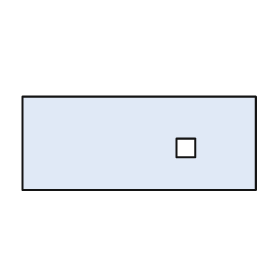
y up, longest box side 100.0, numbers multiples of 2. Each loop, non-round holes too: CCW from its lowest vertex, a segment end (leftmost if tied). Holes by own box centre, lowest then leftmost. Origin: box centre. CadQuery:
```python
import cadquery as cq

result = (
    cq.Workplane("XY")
    .moveTo(-50.0, -20.0)
    .lineTo(50.0, -20.0)
    .lineTo(50.0, 20.0)
    .lineTo(-50.0, 20.0)
    .close()
    .moveTo(16.0, -6.0)
    .lineTo(24.0, -6.0)
    .lineTo(24.0, 2.0)
    .lineTo(16.0, 2.0)
    .close()
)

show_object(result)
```